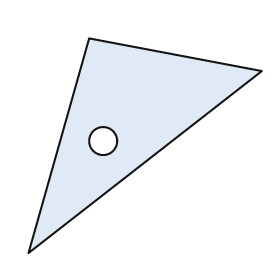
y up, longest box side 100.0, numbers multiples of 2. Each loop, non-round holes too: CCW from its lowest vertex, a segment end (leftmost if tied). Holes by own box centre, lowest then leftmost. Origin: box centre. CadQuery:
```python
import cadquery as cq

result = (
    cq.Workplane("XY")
    .moveTo(-50.0, -46.0)
    .lineTo(50.0, 32.0)
    .lineTo(-24.0, 46.0)
    .close()
    .moveTo(-18.0, 2.0)
    .circle(6.0)
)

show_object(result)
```